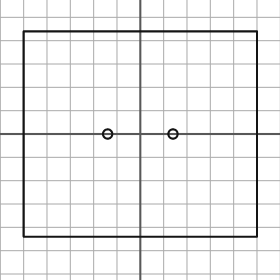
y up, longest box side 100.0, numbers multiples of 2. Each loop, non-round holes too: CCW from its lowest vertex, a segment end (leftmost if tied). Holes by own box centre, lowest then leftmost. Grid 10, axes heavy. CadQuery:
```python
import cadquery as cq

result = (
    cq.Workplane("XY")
    .moveTo(-50.0, -44.0)
    .lineTo(50.0, -44.0)
    .lineTo(50.0, 44.0)
    .lineTo(-50.0, 44.0)
    .close()
    .moveTo(-14.0, 0.0)
    .circle(2.0)
    .moveTo(14.0, 0.0)
    .circle(2.0)
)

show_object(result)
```